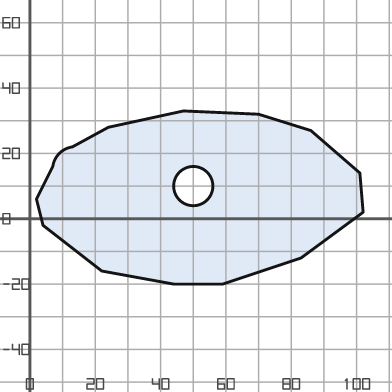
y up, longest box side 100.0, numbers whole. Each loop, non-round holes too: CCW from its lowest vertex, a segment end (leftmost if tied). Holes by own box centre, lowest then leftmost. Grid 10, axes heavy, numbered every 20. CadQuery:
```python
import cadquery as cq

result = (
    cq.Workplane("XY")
    .moveTo(44.0, -20.0)
    .lineTo(59.0, -20.0)
    .lineTo(83.0, -12.0)
    .lineTo(102.0, 2.0)
    .lineTo(101.0, 14.0)
    .lineTo(86.0, 27.0)
    .lineTo(70.0, 32.0)
    .lineTo(47.0, 33.0)
    .lineTo(24.0, 28.0)
    .lineTo(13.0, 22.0)
    .threePointArc((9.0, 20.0), (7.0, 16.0))
    .lineTo(2.0, 6.0)
    .lineTo(4.0, -2.0)
    .lineTo(22.0, -16.0)
    .close()
    .moveTo(50.0, 10.0)
    .circle(6.0)
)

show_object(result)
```